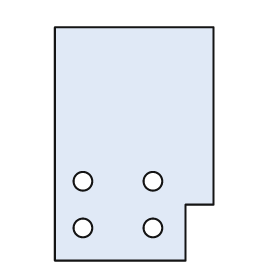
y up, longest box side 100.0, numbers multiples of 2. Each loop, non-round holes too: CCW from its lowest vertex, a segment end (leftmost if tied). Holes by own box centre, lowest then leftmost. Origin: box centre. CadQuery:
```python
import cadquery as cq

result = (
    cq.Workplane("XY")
    .moveTo(-34.0, -50.0)
    .lineTo(22.0, -50.0)
    .lineTo(22.0, -26.0)
    .lineTo(34.0, -26.0)
    .lineTo(34.0, 50.0)
    .lineTo(-34.0, 50.0)
    .close()
    .moveTo(-22.0, -36.0)
    .circle(4.0)
    .moveTo(8.0, -36.0)
    .circle(4.0)
    .moveTo(-22.0, -16.0)
    .circle(4.0)
    .moveTo(8.0, -16.0)
    .circle(4.0)
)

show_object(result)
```